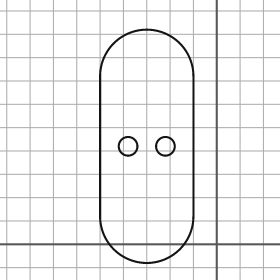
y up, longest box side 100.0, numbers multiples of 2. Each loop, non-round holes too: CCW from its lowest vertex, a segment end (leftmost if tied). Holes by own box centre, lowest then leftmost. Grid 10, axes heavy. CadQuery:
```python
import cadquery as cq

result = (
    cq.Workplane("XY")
    .moveTo(-50.0, 12.0)
    .threePointArc((-30.0, -8.0), (-10.0, 12.0))
    .lineTo(-10.0, 72.0)
    .threePointArc((-30.0, 92.0), (-50.0, 72.0))
    .close()
    .moveTo(-38.0, 42.0)
    .circle(4.0)
    .moveTo(-22.0, 42.0)
    .circle(4.0)
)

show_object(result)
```